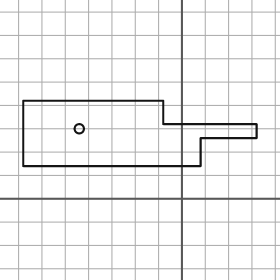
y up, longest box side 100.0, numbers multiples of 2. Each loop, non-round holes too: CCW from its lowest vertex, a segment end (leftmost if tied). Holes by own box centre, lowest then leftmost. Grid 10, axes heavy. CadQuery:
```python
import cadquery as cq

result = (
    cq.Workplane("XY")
    .moveTo(-68.0, 14.0)
    .lineTo(8.0, 14.0)
    .lineTo(8.0, 26.0)
    .lineTo(32.0, 26.0)
    .lineTo(32.0, 32.0)
    .lineTo(-8.0, 32.0)
    .lineTo(-8.0, 42.0)
    .lineTo(-68.0, 42.0)
    .close()
    .moveTo(-44.0, 30.0)
    .circle(2.0)
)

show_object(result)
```